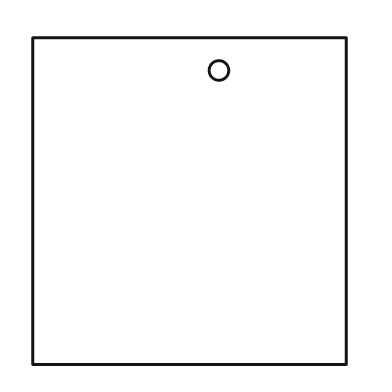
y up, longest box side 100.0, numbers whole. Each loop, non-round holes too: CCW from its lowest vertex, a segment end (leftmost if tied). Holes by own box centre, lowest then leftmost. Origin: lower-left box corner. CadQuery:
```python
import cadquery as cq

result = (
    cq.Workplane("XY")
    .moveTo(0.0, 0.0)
    .lineTo(96.0, 0.0)
    .lineTo(96.0, 100.0)
    .lineTo(0.0, 100.0)
    .close()
    .moveTo(57.0, 90.0)
    .circle(3.0)
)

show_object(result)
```